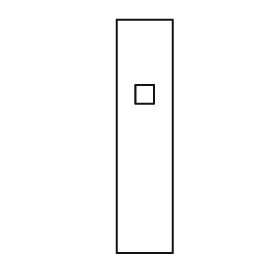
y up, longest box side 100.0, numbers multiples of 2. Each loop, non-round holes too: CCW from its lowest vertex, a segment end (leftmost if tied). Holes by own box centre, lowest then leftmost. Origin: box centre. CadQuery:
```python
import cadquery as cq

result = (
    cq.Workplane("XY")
    .moveTo(-12.0, -50.0)
    .lineTo(12.0, -50.0)
    .lineTo(12.0, 50.0)
    .lineTo(-12.0, 50.0)
    .close()
    .moveTo(-4.0, 14.0)
    .lineTo(4.0, 14.0)
    .lineTo(4.0, 22.0)
    .lineTo(-4.0, 22.0)
    .close()
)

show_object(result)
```